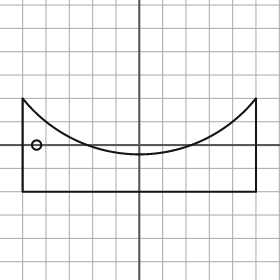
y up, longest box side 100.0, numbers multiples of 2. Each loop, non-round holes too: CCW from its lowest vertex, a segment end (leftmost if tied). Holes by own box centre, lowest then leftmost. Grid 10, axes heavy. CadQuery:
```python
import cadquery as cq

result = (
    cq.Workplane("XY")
    .moveTo(-50.0, -20.0)
    .lineTo(50.0, -20.0)
    .lineTo(50.0, 20.0)
    .threePointArc((0.0, -4.0), (-50.0, 20.0))
    .close()
    .moveTo(-44.0, 0.0)
    .circle(2.0)
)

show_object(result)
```